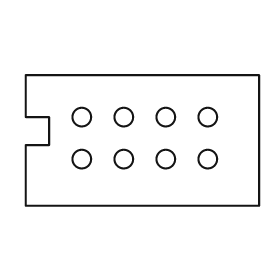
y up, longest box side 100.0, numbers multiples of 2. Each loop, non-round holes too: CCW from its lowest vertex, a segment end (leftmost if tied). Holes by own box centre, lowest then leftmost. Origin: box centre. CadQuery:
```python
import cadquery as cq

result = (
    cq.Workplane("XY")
    .moveTo(-50.0, -28.0)
    .lineTo(50.0, -28.0)
    .lineTo(50.0, 28.0)
    .lineTo(-50.0, 28.0)
    .lineTo(-50.0, 10.0)
    .lineTo(-40.0, 10.0)
    .lineTo(-40.0, -2.0)
    .lineTo(-50.0, -2.0)
    .close()
    .moveTo(-26.0, -8.0)
    .circle(4.0)
    .moveTo(-8.0, -8.0)
    .circle(4.0)
    .moveTo(10.0, -8.0)
    .circle(4.0)
    .moveTo(28.0, -8.0)
    .circle(4.0)
    .moveTo(-26.0, 10.0)
    .circle(4.0)
    .moveTo(-8.0, 10.0)
    .circle(4.0)
    .moveTo(10.0, 10.0)
    .circle(4.0)
    .moveTo(28.0, 10.0)
    .circle(4.0)
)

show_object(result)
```